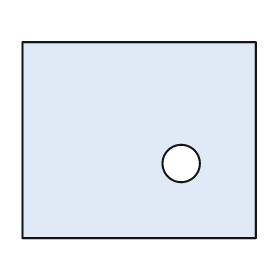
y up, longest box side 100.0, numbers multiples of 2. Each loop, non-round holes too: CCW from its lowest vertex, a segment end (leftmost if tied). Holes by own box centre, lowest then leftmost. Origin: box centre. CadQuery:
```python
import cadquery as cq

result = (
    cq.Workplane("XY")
    .moveTo(-50.0, -42.0)
    .lineTo(50.0, -42.0)
    .lineTo(50.0, 42.0)
    .lineTo(-50.0, 42.0)
    .close()
    .moveTo(18.0, -10.0)
    .circle(8.0)
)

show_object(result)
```